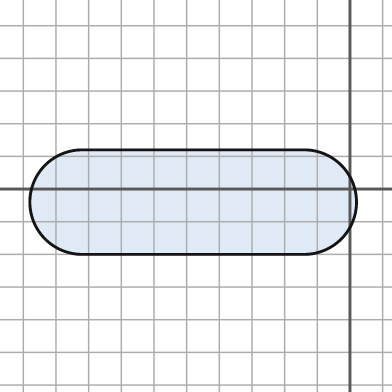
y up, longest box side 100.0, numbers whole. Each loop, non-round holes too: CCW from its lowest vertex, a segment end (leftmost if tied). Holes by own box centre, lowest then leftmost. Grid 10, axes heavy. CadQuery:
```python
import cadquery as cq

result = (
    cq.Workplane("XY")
    .moveTo(-82.0, -20.0)
    .lineTo(-14.0, -20.0)
    .threePointArc((2.0, -4.0), (-14.0, 12.0))
    .lineTo(-82.0, 12.0)
    .threePointArc((-98.0, -4.0), (-82.0, -20.0))
    .close()
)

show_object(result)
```